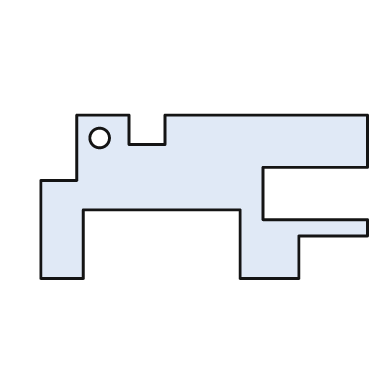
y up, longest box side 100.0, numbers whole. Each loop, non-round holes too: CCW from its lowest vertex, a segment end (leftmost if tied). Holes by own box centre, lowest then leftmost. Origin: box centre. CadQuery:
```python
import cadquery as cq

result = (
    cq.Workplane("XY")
    .moveTo(-50.0, -25.0)
    .lineTo(-37.0, -25.0)
    .lineTo(-37.0, -4.0)
    .lineTo(11.0, -4.0)
    .lineTo(11.0, -25.0)
    .lineTo(29.0, -25.0)
    .lineTo(29.0, -12.0)
    .lineTo(50.0, -12.0)
    .lineTo(50.0, -7.0)
    .lineTo(18.0, -7.0)
    .lineTo(18.0, 9.0)
    .lineTo(50.0, 9.0)
    .lineTo(50.0, 25.0)
    .lineTo(-12.0, 25.0)
    .lineTo(-12.0, 16.0)
    .lineTo(-23.0, 16.0)
    .lineTo(-23.0, 25.0)
    .lineTo(-39.0, 25.0)
    .lineTo(-39.0, 5.0)
    .lineTo(-50.0, 5.0)
    .close()
    .moveTo(-32.0, 18.0)
    .circle(3.0)
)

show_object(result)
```